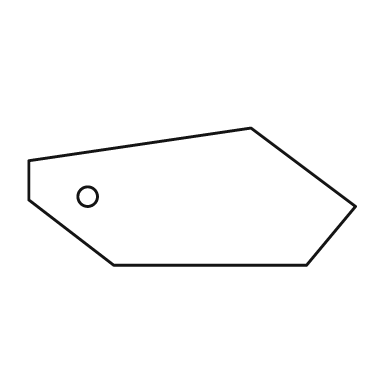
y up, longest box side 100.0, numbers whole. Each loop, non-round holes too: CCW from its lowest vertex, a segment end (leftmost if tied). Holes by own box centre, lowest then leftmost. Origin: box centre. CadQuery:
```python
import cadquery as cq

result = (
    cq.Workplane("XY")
    .moveTo(-24.0, -21.0)
    .lineTo(35.0, -21.0)
    .lineTo(50.0, -3.0)
    .lineTo(18.0, 21.0)
    .lineTo(-50.0, 11.0)
    .lineTo(-50.0, -1.0)
    .close()
    .moveTo(-32.0, 0.0)
    .circle(3.0)
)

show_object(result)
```